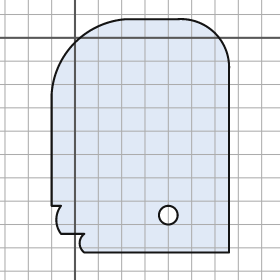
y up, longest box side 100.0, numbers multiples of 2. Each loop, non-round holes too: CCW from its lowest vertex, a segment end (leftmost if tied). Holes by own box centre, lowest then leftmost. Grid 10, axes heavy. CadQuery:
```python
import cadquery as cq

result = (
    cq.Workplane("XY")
    .moveTo(4.0, -92.0)
    .lineTo(66.0, -92.0)
    .lineTo(66.0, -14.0)
    .threePointArc((60.0, 2.0), (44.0, 8.0))
    .lineTo(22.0, 8.0)
    .threePointArc((0.0, -2.0), (-10.0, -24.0))
    .lineTo(-10.0, -72.0)
    .lineTo(-6.0, -72.0)
    .threePointArc((-8.0, -78.0), (-6.0, -84.0))
    .lineTo(4.0, -84.0)
    .threePointArc((2.0, -88.0), (4.0, -92.0))
    .close()
    .moveTo(40.0, -76.0)
    .circle(4.0)
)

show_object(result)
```